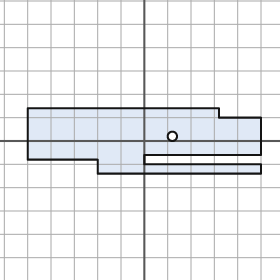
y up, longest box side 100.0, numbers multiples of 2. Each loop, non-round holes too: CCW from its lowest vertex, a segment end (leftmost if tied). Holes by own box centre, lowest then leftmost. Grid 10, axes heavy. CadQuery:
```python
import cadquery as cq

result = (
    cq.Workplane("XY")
    .moveTo(-20.0, -14.0)
    .lineTo(50.0, -14.0)
    .lineTo(50.0, -10.0)
    .lineTo(0.0, -10.0)
    .lineTo(0.0, -6.0)
    .lineTo(50.0, -6.0)
    .lineTo(50.0, 10.0)
    .lineTo(32.0, 10.0)
    .lineTo(32.0, 14.0)
    .lineTo(-50.0, 14.0)
    .lineTo(-50.0, -8.0)
    .lineTo(-20.0, -8.0)
    .close()
    .moveTo(12.0, 2.0)
    .circle(2.0)
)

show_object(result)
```